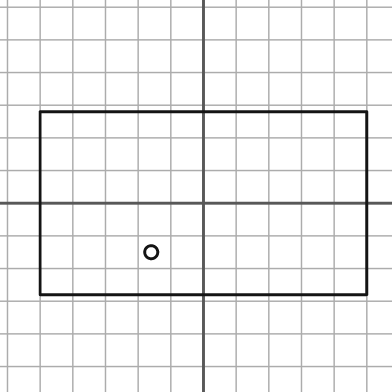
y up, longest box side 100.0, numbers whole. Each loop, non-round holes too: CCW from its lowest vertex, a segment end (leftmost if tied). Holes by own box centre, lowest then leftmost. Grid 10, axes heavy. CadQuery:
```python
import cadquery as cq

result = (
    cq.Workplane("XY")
    .moveTo(-50.0, -28.0)
    .lineTo(50.0, -28.0)
    .lineTo(50.0, 28.0)
    .lineTo(-50.0, 28.0)
    .close()
    .moveTo(-16.0, -15.0)
    .circle(2.0)
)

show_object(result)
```